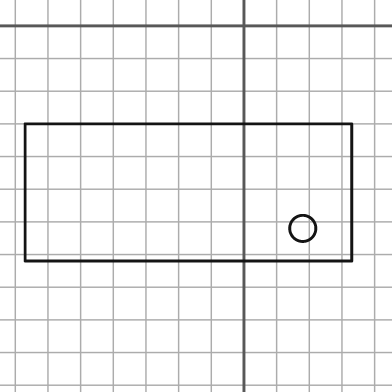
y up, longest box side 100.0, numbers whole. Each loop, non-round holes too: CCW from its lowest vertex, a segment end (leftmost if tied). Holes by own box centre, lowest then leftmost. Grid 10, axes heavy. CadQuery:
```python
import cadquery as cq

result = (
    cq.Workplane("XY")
    .moveTo(-67.0, -72.0)
    .lineTo(33.0, -72.0)
    .lineTo(33.0, -30.0)
    .lineTo(-67.0, -30.0)
    .close()
    .moveTo(18.0, -62.0)
    .circle(4.0)
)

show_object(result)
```